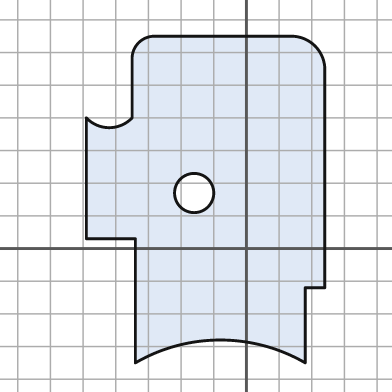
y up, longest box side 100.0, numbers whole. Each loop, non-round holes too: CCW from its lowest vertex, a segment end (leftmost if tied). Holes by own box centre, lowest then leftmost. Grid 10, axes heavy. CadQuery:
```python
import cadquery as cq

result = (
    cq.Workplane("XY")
    .moveTo(-34.0, -35.0)
    .threePointArc((-8.0, -28.0), (18.0, -35.0))
    .lineTo(18.0, -12.0)
    .lineTo(24.0, -12.0)
    .lineTo(24.0, 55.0)
    .threePointArc((21.0, 62.0), (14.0, 65.0))
    .lineTo(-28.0, 65.0)
    .threePointArc((-33.0, 63.0), (-35.0, 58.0))
    .lineTo(-35.0, 40.0)
    .threePointArc((-42.0, 37.0), (-49.0, 40.0))
    .lineTo(-49.0, 3.0)
    .lineTo(-34.0, 3.0)
    .close()
    .moveTo(-16.0, 17.0)
    .circle(6.0)
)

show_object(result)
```